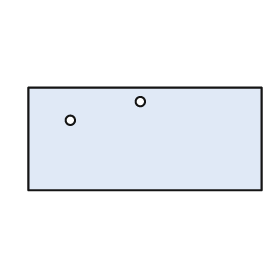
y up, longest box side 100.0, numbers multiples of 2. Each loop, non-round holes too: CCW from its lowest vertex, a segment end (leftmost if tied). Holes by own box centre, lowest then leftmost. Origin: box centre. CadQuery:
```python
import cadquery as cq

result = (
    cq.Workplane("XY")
    .moveTo(-50.0, -22.0)
    .lineTo(50.0, -22.0)
    .lineTo(50.0, 22.0)
    .lineTo(-50.0, 22.0)
    .close()
    .moveTo(-32.0, 8.0)
    .circle(2.0)
    .moveTo(-2.0, 16.0)
    .circle(2.0)
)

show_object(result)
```